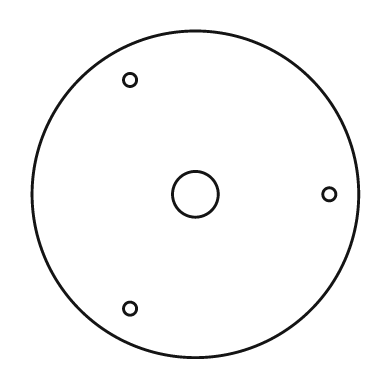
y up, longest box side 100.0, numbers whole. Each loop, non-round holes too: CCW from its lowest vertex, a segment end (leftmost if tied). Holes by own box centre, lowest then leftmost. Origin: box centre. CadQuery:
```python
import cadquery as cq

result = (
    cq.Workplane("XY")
    .moveTo(0.0, 0.0)
    .circle(50.0)
    .moveTo(-20.0, -35.0)
    .circle(2.0)
    .moveTo(0.0, 0.0)
    .circle(7.0)
    .moveTo(41.0, 0.0)
    .circle(2.0)
    .moveTo(-20.0, 35.0)
    .circle(2.0)
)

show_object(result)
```